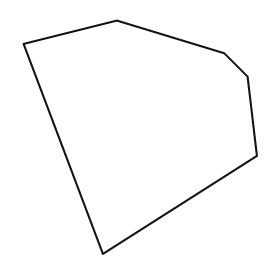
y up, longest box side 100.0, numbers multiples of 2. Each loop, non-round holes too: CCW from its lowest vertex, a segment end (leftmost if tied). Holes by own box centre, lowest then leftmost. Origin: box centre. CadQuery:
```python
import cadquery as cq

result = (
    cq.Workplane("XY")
    .moveTo(-16.0, -50.0)
    .lineTo(50.0, -8.0)
    .lineTo(46.0, 26.0)
    .lineTo(36.0, 36.0)
    .lineTo(-10.0, 50.0)
    .lineTo(-50.0, 40.0)
    .close()
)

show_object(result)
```